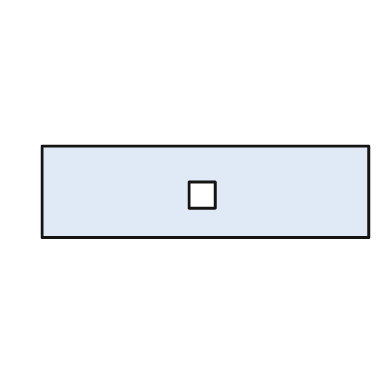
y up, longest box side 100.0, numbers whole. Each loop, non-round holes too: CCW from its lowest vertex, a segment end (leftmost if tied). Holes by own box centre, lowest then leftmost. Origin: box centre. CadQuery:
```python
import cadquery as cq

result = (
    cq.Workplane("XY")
    .moveTo(-50.0, -14.0)
    .lineTo(50.0, -14.0)
    .lineTo(50.0, 14.0)
    .lineTo(-50.0, 14.0)
    .close()
    .moveTo(-5.0, -5.0)
    .lineTo(3.0, -5.0)
    .lineTo(3.0, 3.0)
    .lineTo(-5.0, 3.0)
    .close()
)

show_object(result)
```